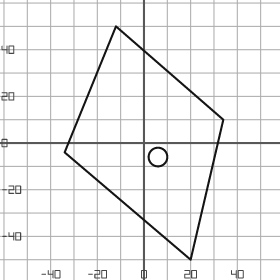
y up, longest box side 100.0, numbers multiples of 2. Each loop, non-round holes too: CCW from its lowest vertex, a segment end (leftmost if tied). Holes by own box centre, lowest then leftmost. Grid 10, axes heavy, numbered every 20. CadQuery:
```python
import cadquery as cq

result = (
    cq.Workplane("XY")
    .moveTo(20.0, -50.0)
    .lineTo(34.0, 10.0)
    .lineTo(-12.0, 50.0)
    .lineTo(-34.0, -4.0)
    .close()
    .moveTo(6.0, -6.0)
    .circle(4.0)
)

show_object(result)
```